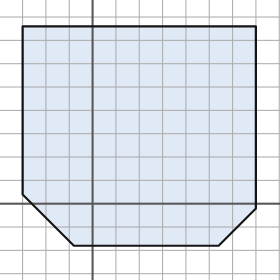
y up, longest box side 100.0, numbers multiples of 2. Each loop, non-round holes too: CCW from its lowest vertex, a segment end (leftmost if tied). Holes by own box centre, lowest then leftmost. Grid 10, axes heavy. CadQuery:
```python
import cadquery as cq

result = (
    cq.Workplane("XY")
    .moveTo(-8.0, -18.0)
    .lineTo(54.0, -18.0)
    .lineTo(70.0, -2.0)
    .lineTo(70.0, 76.0)
    .lineTo(-30.0, 76.0)
    .lineTo(-30.0, 4.0)
    .close()
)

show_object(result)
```